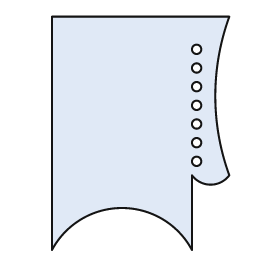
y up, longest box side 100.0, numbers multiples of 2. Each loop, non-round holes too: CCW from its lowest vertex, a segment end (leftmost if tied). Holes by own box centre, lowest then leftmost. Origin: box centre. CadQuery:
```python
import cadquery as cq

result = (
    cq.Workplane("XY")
    .moveTo(-38.0, -50.0)
    .threePointArc((-8.0, -32.0), (22.0, -50.0))
    .lineTo(22.0, -18.0)
    .threePointArc((30.0, -22.0), (38.0, -18.0))
    .threePointArc((32.0, 16.0), (38.0, 50.0))
    .lineTo(-38.0, 50.0)
    .close()
    .moveTo(24.0, -12.0)
    .circle(2.0)
    .moveTo(24.0, -4.0)
    .circle(2.0)
    .moveTo(24.0, 4.0)
    .circle(2.0)
    .moveTo(24.0, 12.0)
    .circle(2.0)
    .moveTo(24.0, 20.0)
    .circle(2.0)
    .moveTo(24.0, 28.0)
    .circle(2.0)
    .moveTo(24.0, 36.0)
    .circle(2.0)
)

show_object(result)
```